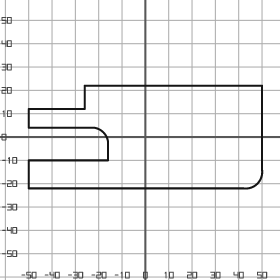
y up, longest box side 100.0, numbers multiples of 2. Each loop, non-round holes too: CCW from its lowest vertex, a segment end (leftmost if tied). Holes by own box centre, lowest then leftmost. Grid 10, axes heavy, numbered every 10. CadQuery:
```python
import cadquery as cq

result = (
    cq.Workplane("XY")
    .moveTo(-50.0, -22.0)
    .lineTo(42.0, -22.0)
    .threePointArc((48.0, -20.0), (50.0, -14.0))
    .lineTo(50.0, 22.0)
    .lineTo(-26.0, 22.0)
    .lineTo(-26.0, 12.0)
    .lineTo(-50.0, 12.0)
    .lineTo(-50.0, 4.0)
    .lineTo(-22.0, 4.0)
    .threePointArc((-18.0, 2.0), (-16.0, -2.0))
    .lineTo(-16.0, -10.0)
    .lineTo(-50.0, -10.0)
    .close()
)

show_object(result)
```